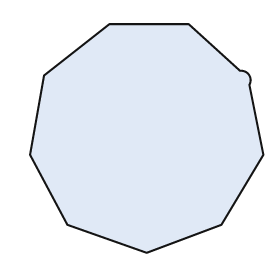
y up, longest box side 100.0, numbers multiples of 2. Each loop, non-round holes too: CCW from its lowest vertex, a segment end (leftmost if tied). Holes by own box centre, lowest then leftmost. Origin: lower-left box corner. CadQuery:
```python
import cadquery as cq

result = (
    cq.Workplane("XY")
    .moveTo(50.0, 0.0)
    .lineTo(82.0, 12.0)
    .lineTo(100.0, 42.0)
    .lineTo(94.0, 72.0)
    .threePointArc((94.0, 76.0), (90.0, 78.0))
    .lineTo(68.0, 98.0)
    .lineTo(34.0, 98.0)
    .lineTo(6.0, 76.0)
    .lineTo(0.0, 42.0)
    .lineTo(16.0, 12.0)
    .close()
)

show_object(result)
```